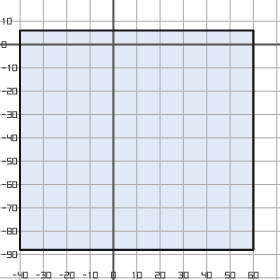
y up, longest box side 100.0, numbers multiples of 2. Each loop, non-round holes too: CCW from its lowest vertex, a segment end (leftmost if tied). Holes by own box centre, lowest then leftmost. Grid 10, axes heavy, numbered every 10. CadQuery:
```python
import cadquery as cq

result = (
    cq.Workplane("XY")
    .moveTo(-40.0, -88.0)
    .lineTo(60.0, -88.0)
    .lineTo(60.0, 6.0)
    .lineTo(-40.0, 6.0)
    .close()
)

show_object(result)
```